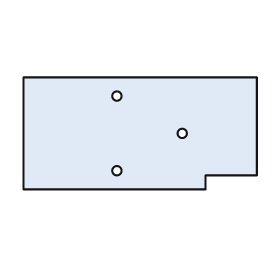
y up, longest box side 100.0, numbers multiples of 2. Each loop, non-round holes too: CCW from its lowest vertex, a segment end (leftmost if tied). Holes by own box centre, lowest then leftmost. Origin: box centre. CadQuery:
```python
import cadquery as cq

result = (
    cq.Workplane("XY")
    .moveTo(-50.0, -24.0)
    .lineTo(28.0, -24.0)
    .lineTo(28.0, -18.0)
    .lineTo(50.0, -18.0)
    .lineTo(50.0, 24.0)
    .lineTo(-50.0, 24.0)
    .close()
    .moveTo(-10.0, -16.0)
    .circle(2.0)
    .moveTo(18.0, 0.0)
    .circle(2.0)
    .moveTo(-10.0, 16.0)
    .circle(2.0)
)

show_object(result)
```